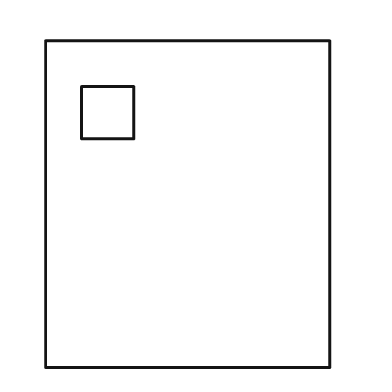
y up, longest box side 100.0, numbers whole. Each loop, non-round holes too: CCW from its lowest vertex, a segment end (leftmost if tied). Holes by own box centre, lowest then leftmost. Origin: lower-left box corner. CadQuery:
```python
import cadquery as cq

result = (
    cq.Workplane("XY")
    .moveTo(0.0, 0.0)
    .lineTo(87.0, 0.0)
    .lineTo(87.0, 100.0)
    .lineTo(0.0, 100.0)
    .close()
    .moveTo(11.0, 70.0)
    .lineTo(27.0, 70.0)
    .lineTo(27.0, 86.0)
    .lineTo(11.0, 86.0)
    .close()
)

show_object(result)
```